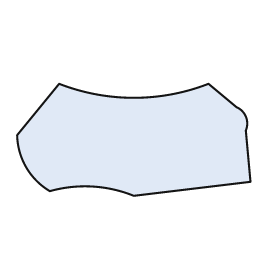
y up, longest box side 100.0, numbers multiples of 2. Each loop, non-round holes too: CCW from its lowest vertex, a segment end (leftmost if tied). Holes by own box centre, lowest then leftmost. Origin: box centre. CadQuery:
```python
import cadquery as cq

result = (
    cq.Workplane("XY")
    .moveTo(0.0, -24.0)
    .lineTo(50.0, -18.0)
    .lineTo(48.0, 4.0)
    .threePointArc((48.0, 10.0), (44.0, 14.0))
    .lineTo(32.0, 24.0)
    .threePointArc((0.0, 18.0), (-32.0, 24.0))
    .lineTo(-50.0, 2.0)
    .threePointArc((-46.0, -12.0), (-36.0, -22.0))
    .threePointArc((-18.0, -20.0), (0.0, -24.0))
    .close()
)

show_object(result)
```